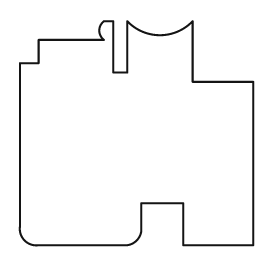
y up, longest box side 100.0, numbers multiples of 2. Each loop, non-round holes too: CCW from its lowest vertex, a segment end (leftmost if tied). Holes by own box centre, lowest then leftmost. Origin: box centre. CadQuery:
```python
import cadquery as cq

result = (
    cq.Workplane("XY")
    .moveTo(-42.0, -48.0)
    .lineTo(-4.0, -48.0)
    .threePointArc((0.0, -46.0), (2.0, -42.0))
    .lineTo(2.0, -30.0)
    .lineTo(20.0, -30.0)
    .lineTo(20.0, -48.0)
    .lineTo(50.0, -48.0)
    .lineTo(50.0, 22.0)
    .lineTo(24.0, 22.0)
    .lineTo(24.0, 48.0)
    .threePointArc((10.0, 42.0), (-4.0, 48.0))
    .lineTo(-4.0, 26.0)
    .lineTo(-10.0, 26.0)
    .lineTo(-10.0, 48.0)
    .lineTo(-14.0, 48.0)
    .threePointArc((-16.0, 44.0), (-14.0, 40.0))
    .lineTo(-42.0, 40.0)
    .lineTo(-42.0, 30.0)
    .lineTo(-50.0, 30.0)
    .lineTo(-50.0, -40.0)
    .threePointArc((-48.0, -46.0), (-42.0, -48.0))
    .close()
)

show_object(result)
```